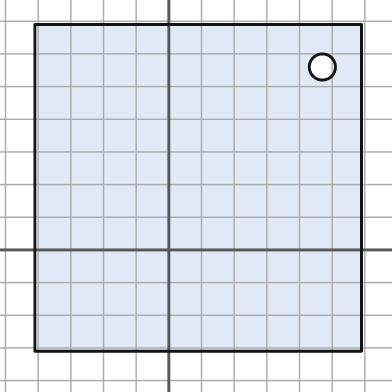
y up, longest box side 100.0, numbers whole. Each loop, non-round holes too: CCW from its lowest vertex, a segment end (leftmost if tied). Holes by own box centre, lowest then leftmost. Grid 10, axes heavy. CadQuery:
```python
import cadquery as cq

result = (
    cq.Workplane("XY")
    .moveTo(-41.0, -31.0)
    .lineTo(59.0, -31.0)
    .lineTo(59.0, 69.0)
    .lineTo(-41.0, 69.0)
    .close()
    .moveTo(47.0, 56.0)
    .circle(4.0)
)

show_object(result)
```